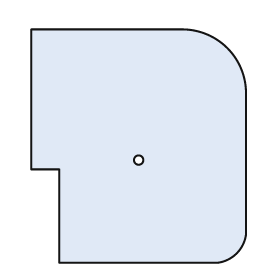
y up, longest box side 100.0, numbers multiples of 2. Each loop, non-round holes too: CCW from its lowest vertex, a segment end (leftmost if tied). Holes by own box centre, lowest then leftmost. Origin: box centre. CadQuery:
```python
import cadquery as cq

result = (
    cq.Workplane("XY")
    .moveTo(-34.0, -50.0)
    .lineTo(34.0, -50.0)
    .threePointArc((42.0, -46.0), (46.0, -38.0))
    .lineTo(46.0, 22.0)
    .threePointArc((38.0, 42.0), (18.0, 50.0))
    .lineTo(-46.0, 50.0)
    .lineTo(-46.0, -10.0)
    .lineTo(-34.0, -10.0)
    .close()
    .moveTo(0.0, -6.0)
    .circle(2.0)
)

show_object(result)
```